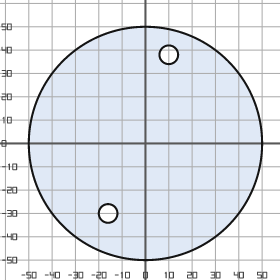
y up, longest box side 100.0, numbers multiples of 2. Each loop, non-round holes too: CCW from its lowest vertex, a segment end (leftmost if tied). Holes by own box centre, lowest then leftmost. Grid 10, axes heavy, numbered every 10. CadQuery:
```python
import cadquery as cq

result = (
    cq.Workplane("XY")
    .moveTo(0.0, 0.0)
    .circle(50.0)
    .moveTo(-16.0, -30.0)
    .circle(4.0)
    .moveTo(10.0, 38.0)
    .circle(4.0)
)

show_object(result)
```